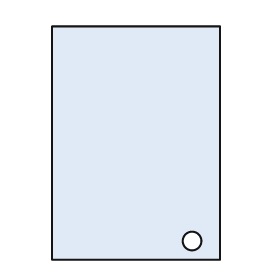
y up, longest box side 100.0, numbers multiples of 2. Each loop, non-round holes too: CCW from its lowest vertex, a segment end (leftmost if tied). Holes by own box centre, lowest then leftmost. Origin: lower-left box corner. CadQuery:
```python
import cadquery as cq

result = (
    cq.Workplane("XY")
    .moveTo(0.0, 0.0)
    .lineTo(72.0, 0.0)
    .lineTo(72.0, 100.0)
    .lineTo(0.0, 100.0)
    .close()
    .moveTo(60.0, 8.0)
    .circle(4.0)
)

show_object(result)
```